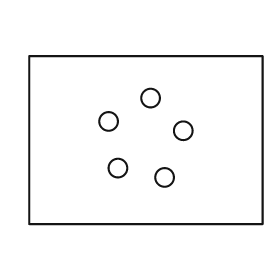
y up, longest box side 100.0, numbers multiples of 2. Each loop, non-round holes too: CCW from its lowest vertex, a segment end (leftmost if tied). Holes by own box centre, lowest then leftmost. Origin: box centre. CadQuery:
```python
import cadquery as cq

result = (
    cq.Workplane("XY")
    .moveTo(-50.0, -36.0)
    .lineTo(50.0, -36.0)
    .lineTo(50.0, 36.0)
    .lineTo(-50.0, 36.0)
    .close()
    .moveTo(8.0, -16.0)
    .circle(4.0)
    .moveTo(-12.0, -12.0)
    .circle(4.0)
    .moveTo(16.0, 4.0)
    .circle(4.0)
    .moveTo(-16.0, 8.0)
    .circle(4.0)
    .moveTo(2.0, 18.0)
    .circle(4.0)
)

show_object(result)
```